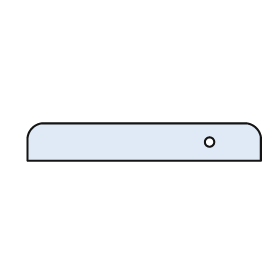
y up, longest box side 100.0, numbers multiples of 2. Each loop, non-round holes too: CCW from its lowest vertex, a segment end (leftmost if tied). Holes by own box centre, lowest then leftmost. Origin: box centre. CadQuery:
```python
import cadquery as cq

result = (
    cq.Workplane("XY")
    .moveTo(-50.0, -8.0)
    .lineTo(50.0, -8.0)
    .lineTo(50.0, 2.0)
    .threePointArc((48.0, 6.0), (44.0, 8.0))
    .lineTo(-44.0, 8.0)
    .threePointArc((-48.0, 6.0), (-50.0, 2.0))
    .close()
    .moveTo(28.0, 0.0)
    .circle(2.0)
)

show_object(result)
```